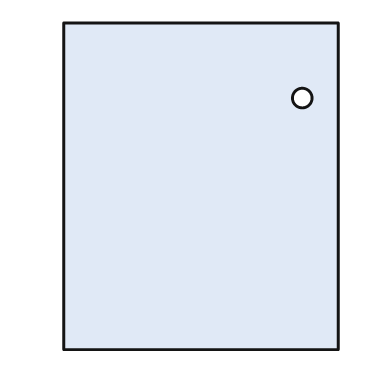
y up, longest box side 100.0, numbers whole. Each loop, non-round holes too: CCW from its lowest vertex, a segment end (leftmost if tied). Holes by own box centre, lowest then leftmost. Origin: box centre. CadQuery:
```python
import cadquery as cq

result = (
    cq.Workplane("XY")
    .moveTo(-42.0, -50.0)
    .lineTo(42.0, -50.0)
    .lineTo(42.0, 50.0)
    .lineTo(-42.0, 50.0)
    .close()
    .moveTo(31.0, 27.0)
    .circle(3.0)
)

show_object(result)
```